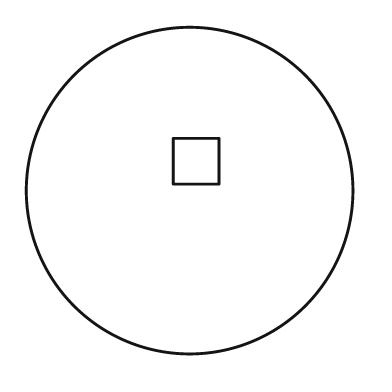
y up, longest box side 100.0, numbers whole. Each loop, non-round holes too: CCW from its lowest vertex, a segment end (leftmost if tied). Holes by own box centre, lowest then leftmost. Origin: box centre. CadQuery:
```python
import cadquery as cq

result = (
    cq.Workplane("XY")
    .moveTo(0.0, 0.0)
    .circle(50.0)
    .moveTo(-5.0, 2.0)
    .lineTo(9.0, 2.0)
    .lineTo(9.0, 16.0)
    .lineTo(-5.0, 16.0)
    .close()
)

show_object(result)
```